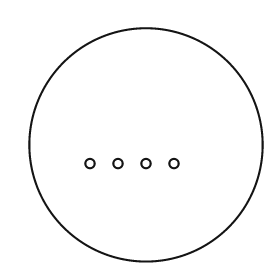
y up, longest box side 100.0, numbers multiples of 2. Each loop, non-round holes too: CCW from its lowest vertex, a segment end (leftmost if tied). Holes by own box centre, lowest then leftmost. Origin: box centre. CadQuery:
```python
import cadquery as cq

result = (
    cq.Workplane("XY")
    .moveTo(0.0, 0.0)
    .circle(50.0)
    .moveTo(-24.0, -8.0)
    .circle(2.0)
    .moveTo(-12.0, -8.0)
    .circle(2.0)
    .moveTo(0.0, -8.0)
    .circle(2.0)
    .moveTo(12.0, -8.0)
    .circle(2.0)
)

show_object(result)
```